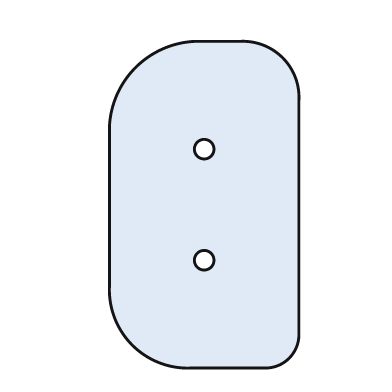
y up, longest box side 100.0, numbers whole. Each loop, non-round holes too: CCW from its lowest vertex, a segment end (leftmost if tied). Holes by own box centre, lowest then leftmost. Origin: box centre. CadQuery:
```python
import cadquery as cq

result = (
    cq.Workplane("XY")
    .moveTo(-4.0, -50.0)
    .lineTo(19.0, -50.0)
    .threePointArc((26.0, -47.0), (29.0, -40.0))
    .lineTo(29.0, 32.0)
    .threePointArc((24.0, 45.0), (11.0, 50.0))
    .lineTo(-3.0, 50.0)
    .threePointArc((-21.0, 42.0), (-29.0, 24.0))
    .lineTo(-29.0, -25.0)
    .threePointArc((-22.0, -43.0), (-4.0, -50.0))
    .close()
    .moveTo(0.0, -17.0)
    .circle(3.0)
    .moveTo(0.0, 17.0)
    .circle(3.0)
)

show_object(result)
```